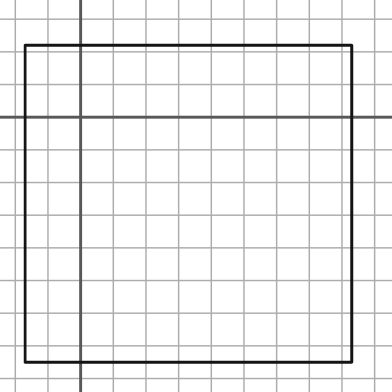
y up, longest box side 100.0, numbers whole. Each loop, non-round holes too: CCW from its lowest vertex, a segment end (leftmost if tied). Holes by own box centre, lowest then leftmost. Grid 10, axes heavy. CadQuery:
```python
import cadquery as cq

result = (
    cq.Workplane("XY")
    .moveTo(-17.0, -75.0)
    .lineTo(83.0, -75.0)
    .lineTo(83.0, 22.0)
    .lineTo(-17.0, 22.0)
    .close()
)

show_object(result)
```